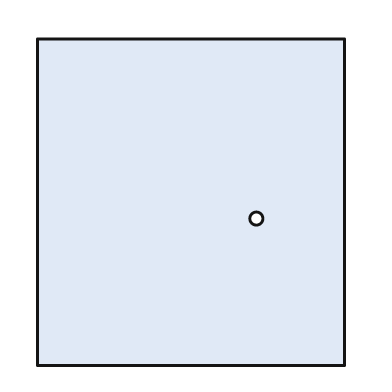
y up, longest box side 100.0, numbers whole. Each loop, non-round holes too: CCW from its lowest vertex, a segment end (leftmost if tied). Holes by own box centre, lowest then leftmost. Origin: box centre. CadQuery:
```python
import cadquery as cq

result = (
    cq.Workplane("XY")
    .moveTo(-47.0, -50.0)
    .lineTo(47.0, -50.0)
    .lineTo(47.0, 50.0)
    .lineTo(-47.0, 50.0)
    .close()
    .moveTo(20.0, -5.0)
    .circle(2.0)
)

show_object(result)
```